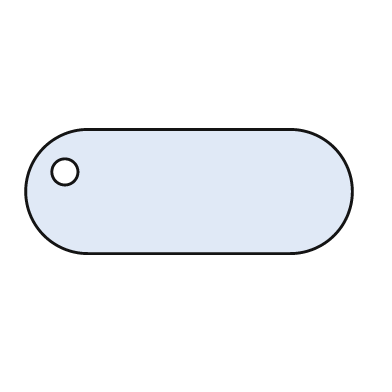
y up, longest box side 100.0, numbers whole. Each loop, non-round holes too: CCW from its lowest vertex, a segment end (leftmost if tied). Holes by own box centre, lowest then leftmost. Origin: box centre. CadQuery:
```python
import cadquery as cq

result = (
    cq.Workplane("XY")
    .moveTo(-31.0, -19.0)
    .lineTo(31.0, -19.0)
    .threePointArc((50.0, 0.0), (31.0, 19.0))
    .lineTo(-31.0, 19.0)
    .threePointArc((-50.0, 0.0), (-31.0, -19.0))
    .close()
    .moveTo(-38.0, 6.0)
    .circle(4.0)
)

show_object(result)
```